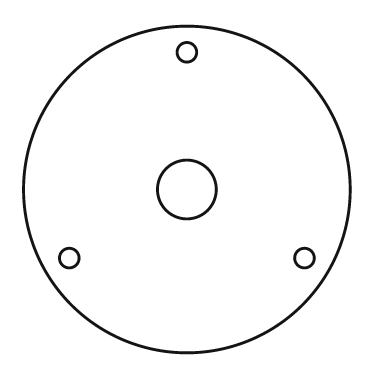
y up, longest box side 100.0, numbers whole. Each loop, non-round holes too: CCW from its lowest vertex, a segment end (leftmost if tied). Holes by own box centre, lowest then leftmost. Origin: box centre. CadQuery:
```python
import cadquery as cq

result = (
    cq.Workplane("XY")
    .moveTo(0.0, 0.0)
    .circle(50.0)
    .moveTo(-36.0, -21.0)
    .circle(3.0)
    .moveTo(36.0, -21.0)
    .circle(3.0)
    .moveTo(0.0, 0.0)
    .circle(9.0)
    .moveTo(0.0, 42.0)
    .circle(3.0)
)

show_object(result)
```